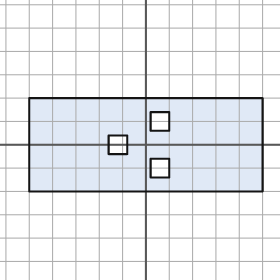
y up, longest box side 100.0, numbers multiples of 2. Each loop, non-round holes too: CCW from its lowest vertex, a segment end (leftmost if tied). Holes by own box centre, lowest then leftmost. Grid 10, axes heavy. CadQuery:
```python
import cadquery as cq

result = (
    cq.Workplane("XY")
    .moveTo(-50.0, -20.0)
    .lineTo(50.0, -20.0)
    .lineTo(50.0, 20.0)
    .lineTo(-50.0, 20.0)
    .close()
    .moveTo(2.0, -14.0)
    .lineTo(10.0, -14.0)
    .lineTo(10.0, -6.0)
    .lineTo(2.0, -6.0)
    .close()
    .moveTo(-16.0, -4.0)
    .lineTo(-8.0, -4.0)
    .lineTo(-8.0, 4.0)
    .lineTo(-16.0, 4.0)
    .close()
    .moveTo(2.0, 6.0)
    .lineTo(10.0, 6.0)
    .lineTo(10.0, 14.0)
    .lineTo(2.0, 14.0)
    .close()
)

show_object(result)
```